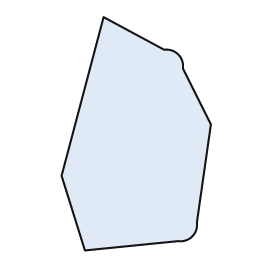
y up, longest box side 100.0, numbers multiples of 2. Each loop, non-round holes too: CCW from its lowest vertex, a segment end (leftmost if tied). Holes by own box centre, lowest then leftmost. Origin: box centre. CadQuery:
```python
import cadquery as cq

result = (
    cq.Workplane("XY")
    .moveTo(-22.0, -50.0)
    .lineTo(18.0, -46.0)
    .threePointArc((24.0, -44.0), (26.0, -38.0))
    .lineTo(32.0, 4.0)
    .lineTo(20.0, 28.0)
    .threePointArc((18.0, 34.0), (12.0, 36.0))
    .lineTo(-14.0, 50.0)
    .lineTo(-32.0, -18.0)
    .close()
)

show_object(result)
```